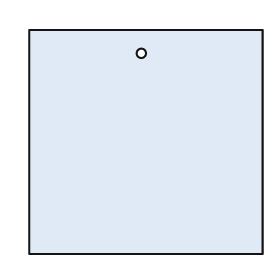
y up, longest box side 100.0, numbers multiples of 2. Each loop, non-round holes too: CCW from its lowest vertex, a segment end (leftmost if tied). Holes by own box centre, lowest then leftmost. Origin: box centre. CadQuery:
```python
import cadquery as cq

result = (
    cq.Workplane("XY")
    .moveTo(-50.0, -48.0)
    .lineTo(50.0, -48.0)
    .lineTo(50.0, 48.0)
    .lineTo(-50.0, 48.0)
    .close()
    .moveTo(-2.0, 38.0)
    .circle(2.0)
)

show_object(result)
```